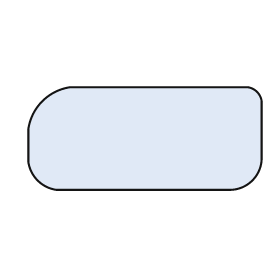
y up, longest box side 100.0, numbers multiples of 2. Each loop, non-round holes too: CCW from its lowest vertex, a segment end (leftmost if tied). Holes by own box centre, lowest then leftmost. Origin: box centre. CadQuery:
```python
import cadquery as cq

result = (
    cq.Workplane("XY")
    .moveTo(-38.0, -22.0)
    .lineTo(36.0, -22.0)
    .threePointArc((46.0, -18.0), (50.0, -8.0))
    .lineTo(50.0, 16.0)
    .threePointArc((48.0, 20.0), (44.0, 22.0))
    .lineTo(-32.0, 22.0)
    .threePointArc((-44.0, 16.0), (-50.0, 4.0))
    .lineTo(-50.0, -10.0)
    .threePointArc((-46.0, -18.0), (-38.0, -22.0))
    .close()
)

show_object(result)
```